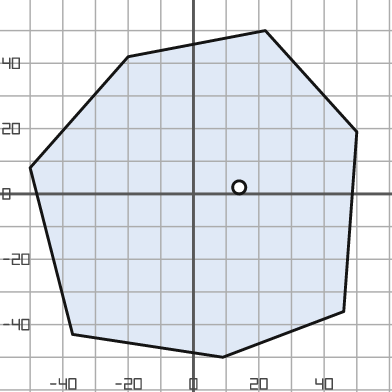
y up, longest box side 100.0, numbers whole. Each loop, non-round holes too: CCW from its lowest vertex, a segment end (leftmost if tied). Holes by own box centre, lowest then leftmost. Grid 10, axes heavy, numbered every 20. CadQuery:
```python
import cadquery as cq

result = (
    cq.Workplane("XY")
    .moveTo(9.0, -50.0)
    .lineTo(46.0, -36.0)
    .lineTo(50.0, 19.0)
    .lineTo(22.0, 50.0)
    .lineTo(-20.0, 42.0)
    .lineTo(-50.0, 8.0)
    .lineTo(-37.0, -43.0)
    .close()
    .moveTo(14.0, 2.0)
    .circle(2.0)
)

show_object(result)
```